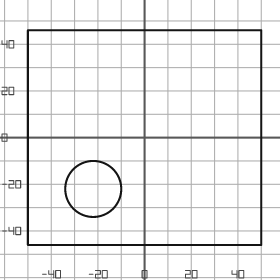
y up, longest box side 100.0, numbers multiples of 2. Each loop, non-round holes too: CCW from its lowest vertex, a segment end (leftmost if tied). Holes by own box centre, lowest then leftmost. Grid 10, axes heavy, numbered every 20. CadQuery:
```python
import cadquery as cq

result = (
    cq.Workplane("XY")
    .moveTo(-50.0, -46.0)
    .lineTo(50.0, -46.0)
    .lineTo(50.0, 46.0)
    .lineTo(-50.0, 46.0)
    .close()
    .moveTo(-22.0, -22.0)
    .circle(12.0)
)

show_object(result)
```